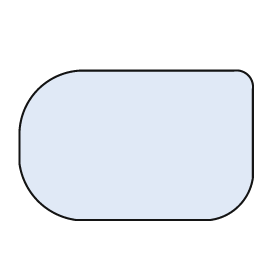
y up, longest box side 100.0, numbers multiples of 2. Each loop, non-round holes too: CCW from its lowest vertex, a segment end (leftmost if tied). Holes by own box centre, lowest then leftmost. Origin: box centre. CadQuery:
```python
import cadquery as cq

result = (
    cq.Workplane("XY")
    .moveTo(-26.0, -32.0)
    .lineTo(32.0, -32.0)
    .threePointArc((44.0, -26.0), (50.0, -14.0))
    .lineTo(50.0, 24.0)
    .threePointArc((48.0, 30.0), (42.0, 32.0))
    .lineTo(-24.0, 32.0)
    .threePointArc((-42.0, 24.0), (-50.0, 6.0))
    .lineTo(-50.0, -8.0)
    .threePointArc((-42.0, -24.0), (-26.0, -32.0))
    .close()
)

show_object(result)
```